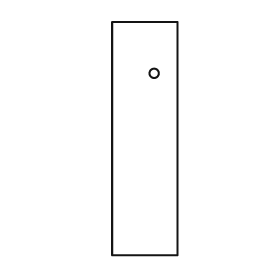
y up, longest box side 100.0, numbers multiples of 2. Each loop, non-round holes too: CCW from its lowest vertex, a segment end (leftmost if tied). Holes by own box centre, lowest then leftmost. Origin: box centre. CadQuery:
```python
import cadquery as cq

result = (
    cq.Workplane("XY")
    .moveTo(-14.0, -50.0)
    .lineTo(14.0, -50.0)
    .lineTo(14.0, 50.0)
    .lineTo(-14.0, 50.0)
    .close()
    .moveTo(4.0, 28.0)
    .circle(2.0)
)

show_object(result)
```